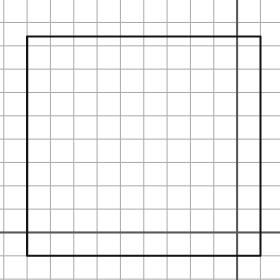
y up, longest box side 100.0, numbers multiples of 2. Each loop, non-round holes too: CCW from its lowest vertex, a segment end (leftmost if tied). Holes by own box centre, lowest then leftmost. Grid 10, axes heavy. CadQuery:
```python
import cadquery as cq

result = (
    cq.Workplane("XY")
    .moveTo(-90.0, -10.0)
    .lineTo(10.0, -10.0)
    .lineTo(10.0, 84.0)
    .lineTo(-90.0, 84.0)
    .close()
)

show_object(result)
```